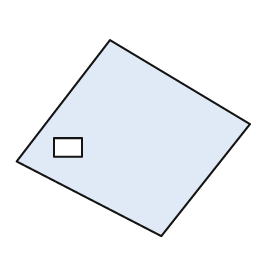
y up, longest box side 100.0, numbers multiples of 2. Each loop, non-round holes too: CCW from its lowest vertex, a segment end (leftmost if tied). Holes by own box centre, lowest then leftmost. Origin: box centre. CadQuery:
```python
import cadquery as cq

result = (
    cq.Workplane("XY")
    .moveTo(12.0, -42.0)
    .lineTo(50.0, 6.0)
    .lineTo(-10.0, 42.0)
    .lineTo(-50.0, -10.0)
    .close()
    .moveTo(-34.0, -8.0)
    .lineTo(-22.0, -8.0)
    .lineTo(-22.0, 0.0)
    .lineTo(-34.0, 0.0)
    .close()
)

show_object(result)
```